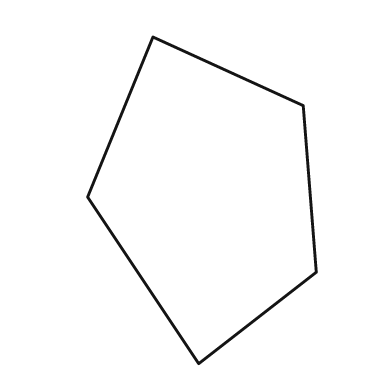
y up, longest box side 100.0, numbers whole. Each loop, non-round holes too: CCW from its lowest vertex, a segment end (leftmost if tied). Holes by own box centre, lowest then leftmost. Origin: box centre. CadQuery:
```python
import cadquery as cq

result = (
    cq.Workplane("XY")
    .moveTo(-1.0, -50.0)
    .lineTo(35.0, -22.0)
    .lineTo(31.0, 29.0)
    .lineTo(-15.0, 50.0)
    .lineTo(-35.0, 1.0)
    .close()
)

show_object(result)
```